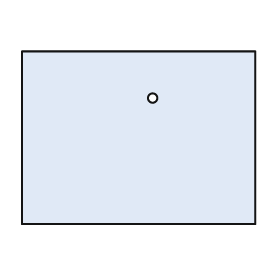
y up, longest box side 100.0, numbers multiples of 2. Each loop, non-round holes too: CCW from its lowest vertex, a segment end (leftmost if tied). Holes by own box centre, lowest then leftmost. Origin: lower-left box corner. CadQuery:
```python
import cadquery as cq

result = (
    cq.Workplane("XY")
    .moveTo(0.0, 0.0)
    .lineTo(100.0, 0.0)
    .lineTo(100.0, 74.0)
    .lineTo(0.0, 74.0)
    .close()
    .moveTo(56.0, 54.0)
    .circle(2.0)
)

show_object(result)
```